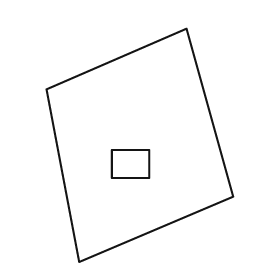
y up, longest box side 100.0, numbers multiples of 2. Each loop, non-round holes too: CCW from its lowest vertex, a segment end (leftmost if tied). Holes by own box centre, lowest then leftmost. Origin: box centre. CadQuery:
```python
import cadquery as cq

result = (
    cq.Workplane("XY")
    .moveTo(-26.0, -50.0)
    .lineTo(40.0, -22.0)
    .lineTo(20.0, 50.0)
    .lineTo(-40.0, 24.0)
    .close()
    .moveTo(-12.0, -14.0)
    .lineTo(4.0, -14.0)
    .lineTo(4.0, -2.0)
    .lineTo(-12.0, -2.0)
    .close()
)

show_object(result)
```